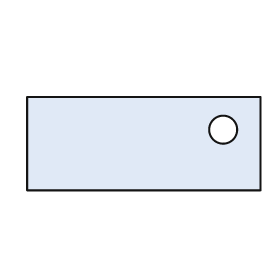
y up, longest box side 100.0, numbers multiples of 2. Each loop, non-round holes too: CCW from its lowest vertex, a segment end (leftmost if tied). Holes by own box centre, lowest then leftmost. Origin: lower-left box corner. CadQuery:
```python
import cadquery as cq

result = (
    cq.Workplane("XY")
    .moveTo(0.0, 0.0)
    .lineTo(100.0, 0.0)
    .lineTo(100.0, 40.0)
    .lineTo(0.0, 40.0)
    .close()
    .moveTo(84.0, 26.0)
    .circle(6.0)
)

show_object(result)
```